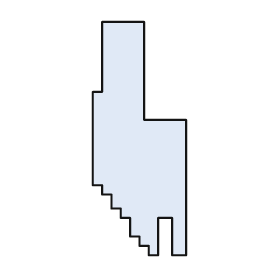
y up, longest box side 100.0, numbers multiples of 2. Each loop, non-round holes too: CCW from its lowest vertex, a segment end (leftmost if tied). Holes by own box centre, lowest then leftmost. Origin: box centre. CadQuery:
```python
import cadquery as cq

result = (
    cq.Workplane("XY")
    .moveTo(4.0, -50.0)
    .lineTo(8.0, -50.0)
    .lineTo(8.0, -34.0)
    .lineTo(14.0, -34.0)
    .lineTo(14.0, -50.0)
    .lineTo(20.0, -50.0)
    .lineTo(20.0, 8.0)
    .lineTo(2.0, 8.0)
    .lineTo(2.0, 50.0)
    .lineTo(-16.0, 50.0)
    .lineTo(-16.0, 20.0)
    .lineTo(-20.0, 20.0)
    .lineTo(-20.0, -20.0)
    .lineTo(-16.0, -20.0)
    .lineTo(-16.0, -24.0)
    .lineTo(-12.0, -24.0)
    .lineTo(-12.0, -30.0)
    .lineTo(-8.0, -30.0)
    .lineTo(-8.0, -34.0)
    .lineTo(-4.0, -34.0)
    .lineTo(-4.0, -42.0)
    .lineTo(0.0, -42.0)
    .lineTo(0.0, -46.0)
    .lineTo(4.0, -46.0)
    .close()
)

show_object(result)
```